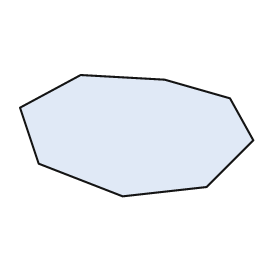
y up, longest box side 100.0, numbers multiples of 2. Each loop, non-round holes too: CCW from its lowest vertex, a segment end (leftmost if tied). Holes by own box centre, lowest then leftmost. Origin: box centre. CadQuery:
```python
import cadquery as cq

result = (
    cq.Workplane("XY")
    .moveTo(-6.0, -26.0)
    .lineTo(30.0, -22.0)
    .lineTo(50.0, -2.0)
    .lineTo(40.0, 16.0)
    .lineTo(12.0, 24.0)
    .lineTo(-24.0, 26.0)
    .lineTo(-50.0, 12.0)
    .lineTo(-42.0, -12.0)
    .close()
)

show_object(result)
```